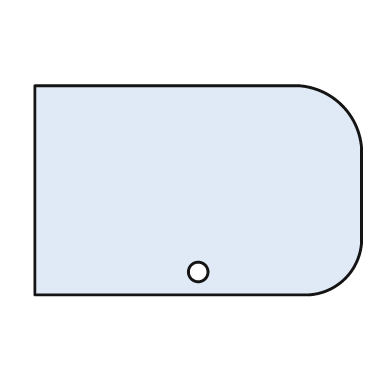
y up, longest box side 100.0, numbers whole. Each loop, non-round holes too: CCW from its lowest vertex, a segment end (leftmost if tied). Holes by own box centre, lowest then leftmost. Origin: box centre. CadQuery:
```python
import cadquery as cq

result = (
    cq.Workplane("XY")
    .moveTo(-50.0, -32.0)
    .lineTo(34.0, -32.0)
    .threePointArc((45.0, -27.0), (50.0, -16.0))
    .lineTo(50.0, 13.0)
    .threePointArc((44.0, 26.0), (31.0, 32.0))
    .lineTo(-50.0, 32.0)
    .close()
    .moveTo(0.0, -25.0)
    .circle(3.0)
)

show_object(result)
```